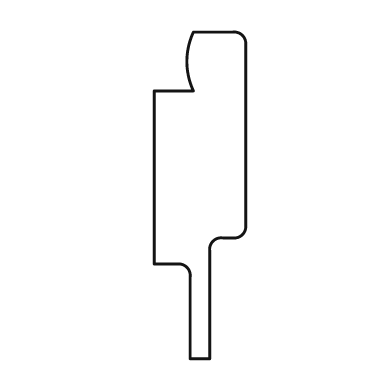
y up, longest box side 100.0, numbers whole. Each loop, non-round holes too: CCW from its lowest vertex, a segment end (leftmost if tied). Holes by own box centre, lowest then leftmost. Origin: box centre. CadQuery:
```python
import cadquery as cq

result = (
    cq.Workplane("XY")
    .moveTo(-3.0, -50.0)
    .lineTo(3.0, -50.0)
    .lineTo(3.0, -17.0)
    .threePointArc((4.0, -14.0), (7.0, -13.0))
    .lineTo(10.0, -13.0)
    .threePointArc((13.0, -12.0), (14.0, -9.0))
    .lineTo(14.0, 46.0)
    .threePointArc((13.0, 49.0), (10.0, 50.0))
    .lineTo(-2.0, 50.0)
    .threePointArc((-4.0, 41.0), (-2.0, 32.0))
    .lineTo(-14.0, 32.0)
    .lineTo(-14.0, -21.0)
    .lineTo(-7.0, -21.0)
    .threePointArc((-4.0, -22.0), (-3.0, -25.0))
    .close()
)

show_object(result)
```